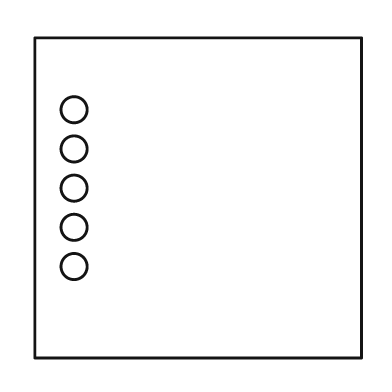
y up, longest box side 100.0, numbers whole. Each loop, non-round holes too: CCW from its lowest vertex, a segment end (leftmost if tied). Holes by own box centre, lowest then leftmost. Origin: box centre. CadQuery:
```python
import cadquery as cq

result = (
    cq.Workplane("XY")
    .moveTo(-50.0, -49.0)
    .lineTo(50.0, -49.0)
    .lineTo(50.0, 49.0)
    .lineTo(-50.0, 49.0)
    .close()
    .moveTo(-38.0, -21.0)
    .circle(4.0)
    .moveTo(-38.0, -9.0)
    .circle(4.0)
    .moveTo(-38.0, 3.0)
    .circle(4.0)
    .moveTo(-38.0, 15.0)
    .circle(4.0)
    .moveTo(-38.0, 27.0)
    .circle(4.0)
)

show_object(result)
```